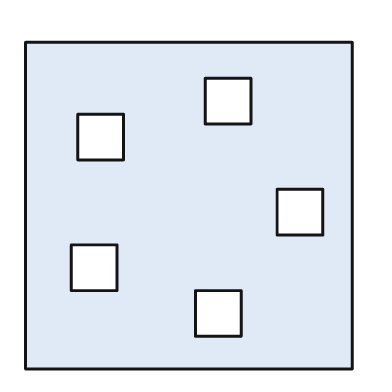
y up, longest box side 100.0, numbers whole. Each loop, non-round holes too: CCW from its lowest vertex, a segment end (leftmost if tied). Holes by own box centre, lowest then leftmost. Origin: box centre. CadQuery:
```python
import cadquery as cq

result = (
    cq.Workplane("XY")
    .moveTo(-50.0, -50.0)
    .lineTo(50.0, -50.0)
    .lineTo(50.0, 50.0)
    .lineTo(-50.0, 50.0)
    .close()
    .moveTo(2.0, -40.0)
    .lineTo(16.0, -40.0)
    .lineTo(16.0, -26.0)
    .lineTo(2.0, -26.0)
    .close()
    .moveTo(-36.0, -26.0)
    .lineTo(-22.0, -26.0)
    .lineTo(-22.0, -12.0)
    .lineTo(-36.0, -12.0)
    .close()
    .moveTo(27.0, -9.0)
    .lineTo(41.0, -9.0)
    .lineTo(41.0, 5.0)
    .lineTo(27.0, 5.0)
    .close()
    .moveTo(-34.0, 14.0)
    .lineTo(-20.0, 14.0)
    .lineTo(-20.0, 28.0)
    .lineTo(-34.0, 28.0)
    .close()
    .moveTo(5.0, 25.0)
    .lineTo(19.0, 25.0)
    .lineTo(19.0, 39.0)
    .lineTo(5.0, 39.0)
    .close()
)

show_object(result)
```